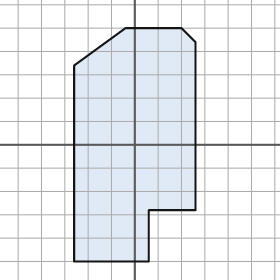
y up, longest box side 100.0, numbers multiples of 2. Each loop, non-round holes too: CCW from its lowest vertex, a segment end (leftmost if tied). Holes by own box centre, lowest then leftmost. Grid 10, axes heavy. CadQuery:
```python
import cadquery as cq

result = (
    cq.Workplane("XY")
    .moveTo(-26.0, -50.0)
    .lineTo(6.0, -50.0)
    .lineTo(6.0, -28.0)
    .lineTo(26.0, -28.0)
    .lineTo(26.0, 44.0)
    .lineTo(20.0, 50.0)
    .lineTo(-4.0, 50.0)
    .lineTo(-26.0, 34.0)
    .close()
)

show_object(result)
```